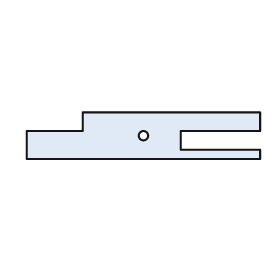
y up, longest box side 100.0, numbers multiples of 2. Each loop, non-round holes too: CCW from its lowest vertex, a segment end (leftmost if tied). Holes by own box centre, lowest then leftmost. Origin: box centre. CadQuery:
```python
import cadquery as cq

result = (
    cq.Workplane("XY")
    .moveTo(-50.0, -10.0)
    .lineTo(50.0, -10.0)
    .lineTo(50.0, -6.0)
    .lineTo(16.0, -6.0)
    .lineTo(16.0, 2.0)
    .lineTo(50.0, 2.0)
    .lineTo(50.0, 10.0)
    .lineTo(-26.0, 10.0)
    .lineTo(-26.0, 2.0)
    .lineTo(-50.0, 2.0)
    .close()
    .moveTo(0.0, 0.0)
    .circle(2.0)
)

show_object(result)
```